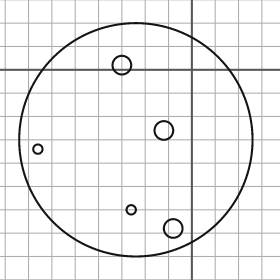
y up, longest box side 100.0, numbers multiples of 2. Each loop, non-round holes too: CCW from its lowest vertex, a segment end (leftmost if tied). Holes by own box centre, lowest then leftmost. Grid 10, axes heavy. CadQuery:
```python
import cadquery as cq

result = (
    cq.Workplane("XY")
    .moveTo(-24.0, -30.0)
    .circle(50.0)
    .moveTo(-8.0, -68.0)
    .circle(4.0)
    .moveTo(-26.0, -60.0)
    .circle(2.0)
    .moveTo(-66.0, -34.0)
    .circle(2.0)
    .moveTo(-12.0, -26.0)
    .circle(4.0)
    .moveTo(-30.0, 2.0)
    .circle(4.0)
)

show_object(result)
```